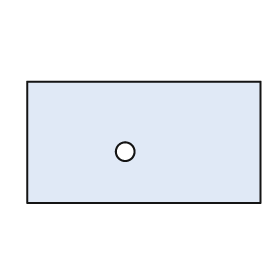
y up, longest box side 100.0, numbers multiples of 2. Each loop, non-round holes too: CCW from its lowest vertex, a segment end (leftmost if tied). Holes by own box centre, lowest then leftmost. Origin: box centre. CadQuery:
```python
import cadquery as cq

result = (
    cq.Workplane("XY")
    .moveTo(-50.0, -26.0)
    .lineTo(50.0, -26.0)
    .lineTo(50.0, 26.0)
    .lineTo(-50.0, 26.0)
    .close()
    .moveTo(-8.0, -4.0)
    .circle(4.0)
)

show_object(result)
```